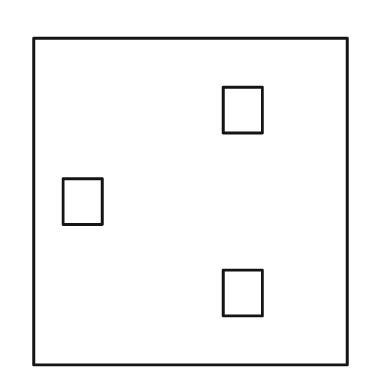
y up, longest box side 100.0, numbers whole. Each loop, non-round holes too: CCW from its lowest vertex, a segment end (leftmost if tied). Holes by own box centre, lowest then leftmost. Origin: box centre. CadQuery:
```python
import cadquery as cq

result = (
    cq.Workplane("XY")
    .moveTo(-48.0, -50.0)
    .lineTo(48.0, -50.0)
    .lineTo(48.0, 50.0)
    .lineTo(-48.0, 50.0)
    .close()
    .moveTo(10.0, -35.0)
    .lineTo(22.0, -35.0)
    .lineTo(22.0, -21.0)
    .lineTo(10.0, -21.0)
    .close()
    .moveTo(-39.0, -7.0)
    .lineTo(-27.0, -7.0)
    .lineTo(-27.0, 7.0)
    .lineTo(-39.0, 7.0)
    .close()
    .moveTo(10.0, 21.0)
    .lineTo(22.0, 21.0)
    .lineTo(22.0, 35.0)
    .lineTo(10.0, 35.0)
    .close()
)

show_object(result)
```